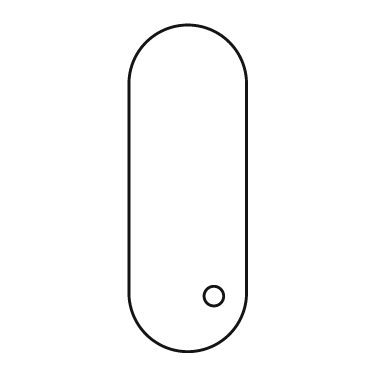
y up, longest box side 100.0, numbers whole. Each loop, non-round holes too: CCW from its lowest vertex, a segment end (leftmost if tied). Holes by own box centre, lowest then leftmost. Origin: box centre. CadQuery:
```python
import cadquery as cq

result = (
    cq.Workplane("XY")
    .moveTo(-18.0, -32.0)
    .threePointArc((0.0, -50.0), (18.0, -32.0))
    .lineTo(18.0, 32.0)
    .threePointArc((0.0, 50.0), (-18.0, 32.0))
    .close()
    .moveTo(8.0, -33.0)
    .circle(3.0)
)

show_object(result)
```